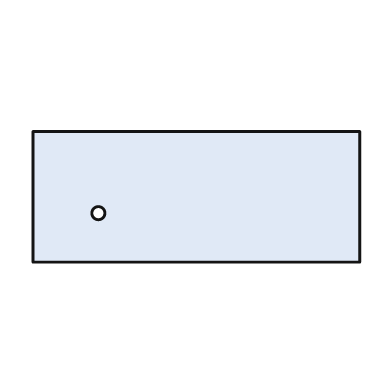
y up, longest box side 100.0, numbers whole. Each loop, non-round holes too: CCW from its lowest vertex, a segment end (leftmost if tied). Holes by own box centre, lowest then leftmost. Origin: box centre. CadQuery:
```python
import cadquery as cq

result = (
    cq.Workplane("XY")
    .moveTo(-50.0, -20.0)
    .lineTo(50.0, -20.0)
    .lineTo(50.0, 20.0)
    .lineTo(-50.0, 20.0)
    .close()
    .moveTo(-30.0, -5.0)
    .circle(2.0)
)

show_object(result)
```